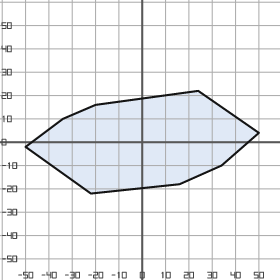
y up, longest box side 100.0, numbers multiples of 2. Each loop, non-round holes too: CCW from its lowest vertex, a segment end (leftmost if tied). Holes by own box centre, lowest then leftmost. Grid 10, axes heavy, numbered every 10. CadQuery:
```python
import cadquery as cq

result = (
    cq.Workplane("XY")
    .moveTo(-22.0, -22.0)
    .lineTo(16.0, -18.0)
    .lineTo(34.0, -10.0)
    .lineTo(50.0, 4.0)
    .lineTo(24.0, 22.0)
    .lineTo(-20.0, 16.0)
    .lineTo(-34.0, 10.0)
    .lineTo(-50.0, -2.0)
    .close()
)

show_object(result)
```